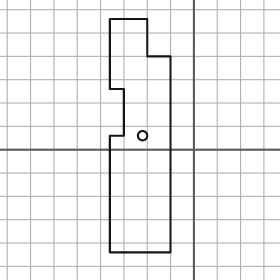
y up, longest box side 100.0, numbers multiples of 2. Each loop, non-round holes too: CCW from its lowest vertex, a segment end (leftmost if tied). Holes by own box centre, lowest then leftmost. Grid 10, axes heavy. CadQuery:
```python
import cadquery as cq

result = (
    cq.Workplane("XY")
    .moveTo(-36.0, -44.0)
    .lineTo(-10.0, -44.0)
    .lineTo(-10.0, 40.0)
    .lineTo(-20.0, 40.0)
    .lineTo(-20.0, 56.0)
    .lineTo(-36.0, 56.0)
    .lineTo(-36.0, 26.0)
    .lineTo(-30.0, 26.0)
    .lineTo(-30.0, 6.0)
    .lineTo(-36.0, 6.0)
    .close()
    .moveTo(-22.0, 6.0)
    .circle(2.0)
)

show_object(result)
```